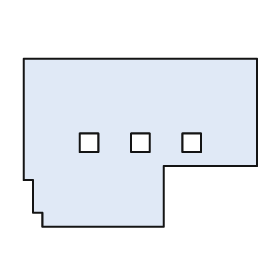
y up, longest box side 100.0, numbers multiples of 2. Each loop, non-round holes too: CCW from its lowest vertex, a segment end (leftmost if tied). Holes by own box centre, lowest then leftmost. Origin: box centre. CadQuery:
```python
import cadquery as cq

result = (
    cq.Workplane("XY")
    .moveTo(-42.0, -36.0)
    .lineTo(10.0, -36.0)
    .lineTo(10.0, -10.0)
    .lineTo(50.0, -10.0)
    .lineTo(50.0, 36.0)
    .lineTo(-50.0, 36.0)
    .lineTo(-50.0, -16.0)
    .lineTo(-46.0, -16.0)
    .lineTo(-46.0, -30.0)
    .lineTo(-42.0, -30.0)
    .close()
    .moveTo(-26.0, -4.0)
    .lineTo(-18.0, -4.0)
    .lineTo(-18.0, 4.0)
    .lineTo(-26.0, 4.0)
    .close()
    .moveTo(-4.0, -4.0)
    .lineTo(4.0, -4.0)
    .lineTo(4.0, 4.0)
    .lineTo(-4.0, 4.0)
    .close()
    .moveTo(18.0, -4.0)
    .lineTo(26.0, -4.0)
    .lineTo(26.0, 4.0)
    .lineTo(18.0, 4.0)
    .close()
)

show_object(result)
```